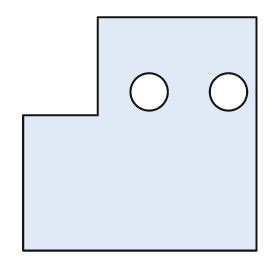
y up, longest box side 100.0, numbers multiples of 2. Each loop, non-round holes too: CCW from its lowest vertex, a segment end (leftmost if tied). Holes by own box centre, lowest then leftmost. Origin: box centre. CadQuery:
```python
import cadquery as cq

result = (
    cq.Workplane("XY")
    .moveTo(-50.0, -50.0)
    .lineTo(50.0, -50.0)
    .lineTo(50.0, 50.0)
    .lineTo(-18.0, 50.0)
    .lineTo(-18.0, 8.0)
    .lineTo(-50.0, 8.0)
    .close()
    .moveTo(4.0, 18.0)
    .circle(8.0)
    .moveTo(38.0, 18.0)
    .circle(8.0)
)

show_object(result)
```